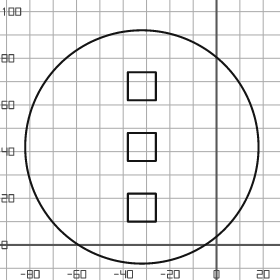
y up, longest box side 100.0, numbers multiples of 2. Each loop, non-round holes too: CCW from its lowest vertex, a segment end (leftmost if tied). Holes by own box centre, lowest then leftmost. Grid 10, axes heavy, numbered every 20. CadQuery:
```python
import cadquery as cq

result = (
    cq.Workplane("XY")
    .moveTo(-32.0, 42.0)
    .circle(50.0)
    .moveTo(-38.0, 10.0)
    .lineTo(-26.0, 10.0)
    .lineTo(-26.0, 22.0)
    .lineTo(-38.0, 22.0)
    .close()
    .moveTo(-38.0, 36.0)
    .lineTo(-26.0, 36.0)
    .lineTo(-26.0, 48.0)
    .lineTo(-38.0, 48.0)
    .close()
    .moveTo(-38.0, 62.0)
    .lineTo(-26.0, 62.0)
    .lineTo(-26.0, 74.0)
    .lineTo(-38.0, 74.0)
    .close()
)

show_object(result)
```